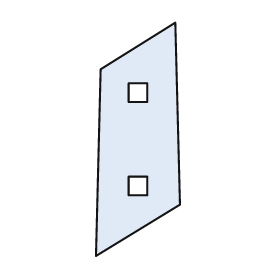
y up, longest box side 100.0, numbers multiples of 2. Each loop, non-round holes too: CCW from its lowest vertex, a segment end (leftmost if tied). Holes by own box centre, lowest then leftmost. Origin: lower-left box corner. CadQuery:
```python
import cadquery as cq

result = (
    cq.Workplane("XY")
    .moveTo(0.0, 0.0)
    .lineTo(36.0, 22.0)
    .lineTo(34.0, 100.0)
    .lineTo(2.0, 80.0)
    .close()
    .moveTo(14.0, 26.0)
    .lineTo(22.0, 26.0)
    .lineTo(22.0, 34.0)
    .lineTo(14.0, 34.0)
    .close()
    .moveTo(14.0, 66.0)
    .lineTo(22.0, 66.0)
    .lineTo(22.0, 74.0)
    .lineTo(14.0, 74.0)
    .close()
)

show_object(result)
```